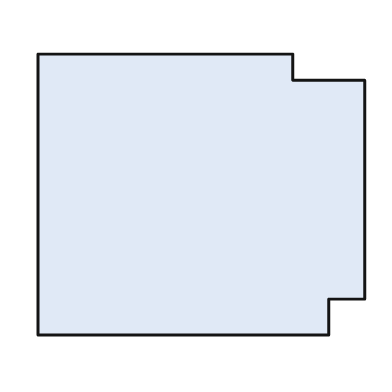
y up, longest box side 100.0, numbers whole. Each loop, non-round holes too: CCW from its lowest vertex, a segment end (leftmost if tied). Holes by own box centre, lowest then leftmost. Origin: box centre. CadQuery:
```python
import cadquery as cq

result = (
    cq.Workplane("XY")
    .moveTo(-50.0, -43.0)
    .lineTo(39.0, -43.0)
    .lineTo(39.0, -32.0)
    .lineTo(50.0, -32.0)
    .lineTo(50.0, 35.0)
    .lineTo(28.0, 35.0)
    .lineTo(28.0, 43.0)
    .lineTo(-50.0, 43.0)
    .close()
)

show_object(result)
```